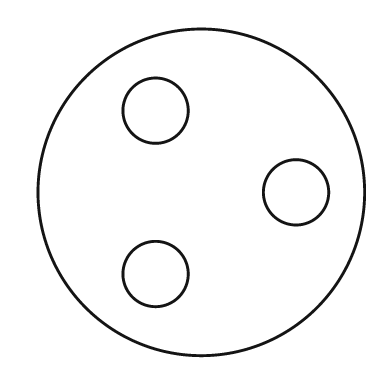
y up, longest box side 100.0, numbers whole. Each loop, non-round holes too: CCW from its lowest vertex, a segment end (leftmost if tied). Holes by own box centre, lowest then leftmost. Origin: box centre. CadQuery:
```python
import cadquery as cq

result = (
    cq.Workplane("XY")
    .moveTo(0.0, 0.0)
    .circle(50.0)
    .moveTo(-14.0, -25.0)
    .circle(10.0)
    .moveTo(29.0, 0.0)
    .circle(10.0)
    .moveTo(-14.0, 25.0)
    .circle(10.0)
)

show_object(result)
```